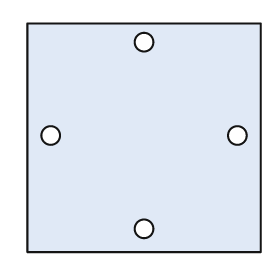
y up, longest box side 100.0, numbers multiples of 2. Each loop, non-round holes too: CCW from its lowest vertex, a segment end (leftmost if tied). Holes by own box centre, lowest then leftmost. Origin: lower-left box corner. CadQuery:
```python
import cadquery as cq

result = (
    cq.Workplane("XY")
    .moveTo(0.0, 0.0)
    .lineTo(100.0, 0.0)
    .lineTo(100.0, 98.0)
    .lineTo(0.0, 98.0)
    .close()
    .moveTo(50.0, 10.0)
    .circle(4.0)
    .moveTo(10.0, 50.0)
    .circle(4.0)
    .moveTo(90.0, 50.0)
    .circle(4.0)
    .moveTo(50.0, 90.0)
    .circle(4.0)
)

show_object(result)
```